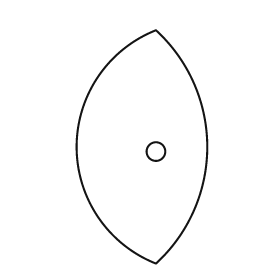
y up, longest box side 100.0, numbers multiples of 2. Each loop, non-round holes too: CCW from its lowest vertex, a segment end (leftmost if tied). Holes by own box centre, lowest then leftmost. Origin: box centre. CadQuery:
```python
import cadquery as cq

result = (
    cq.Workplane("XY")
    .moveTo(6.0, -50.0)
    .threePointArc((28.0, 0.0), (6.0, 50.0))
    .threePointArc((-28.0, 0.0), (6.0, -50.0))
    .close()
    .moveTo(6.0, -2.0)
    .circle(4.0)
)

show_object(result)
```